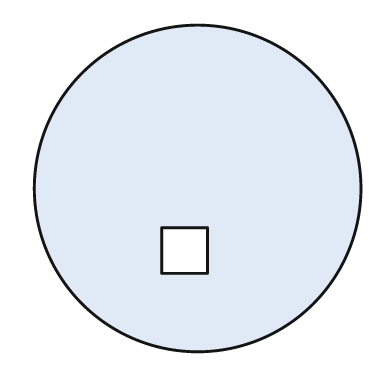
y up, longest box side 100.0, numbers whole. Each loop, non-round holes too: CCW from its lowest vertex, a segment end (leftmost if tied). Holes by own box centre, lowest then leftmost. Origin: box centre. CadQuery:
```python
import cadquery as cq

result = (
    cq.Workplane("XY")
    .moveTo(0.0, 0.0)
    .circle(50.0)
    .moveTo(-11.0, -26.0)
    .lineTo(3.0, -26.0)
    .lineTo(3.0, -12.0)
    .lineTo(-11.0, -12.0)
    .close()
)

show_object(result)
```